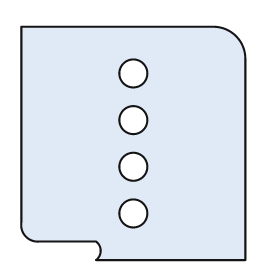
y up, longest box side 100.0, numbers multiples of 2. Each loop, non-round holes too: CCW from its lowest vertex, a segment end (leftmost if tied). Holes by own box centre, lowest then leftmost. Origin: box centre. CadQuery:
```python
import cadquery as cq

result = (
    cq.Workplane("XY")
    .moveTo(-16.0, -50.0)
    .lineTo(48.0, -50.0)
    .lineTo(48.0, 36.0)
    .threePointArc((44.0, 46.0), (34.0, 50.0))
    .lineTo(-48.0, 50.0)
    .lineTo(-48.0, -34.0)
    .threePointArc((-46.0, -40.0), (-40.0, -42.0))
    .lineTo(-16.0, -42.0)
    .threePointArc((-14.0, -46.0), (-16.0, -50.0))
    .close()
    .moveTo(0.0, -30.0)
    .circle(6.0)
    .moveTo(0.0, -10.0)
    .circle(6.0)
    .moveTo(0.0, 10.0)
    .circle(6.0)
    .moveTo(0.0, 30.0)
    .circle(6.0)
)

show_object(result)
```